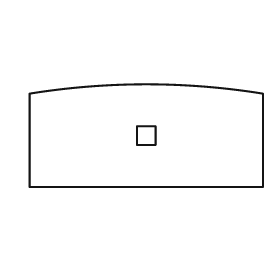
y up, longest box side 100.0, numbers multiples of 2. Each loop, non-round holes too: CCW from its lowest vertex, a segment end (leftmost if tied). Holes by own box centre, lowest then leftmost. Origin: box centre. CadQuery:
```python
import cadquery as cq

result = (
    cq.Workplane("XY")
    .moveTo(-50.0, -22.0)
    .lineTo(50.0, -22.0)
    .lineTo(50.0, 18.0)
    .threePointArc((0.0, 22.0), (-50.0, 18.0))
    .close()
    .moveTo(-4.0, -4.0)
    .lineTo(4.0, -4.0)
    .lineTo(4.0, 4.0)
    .lineTo(-4.0, 4.0)
    .close()
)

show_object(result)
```